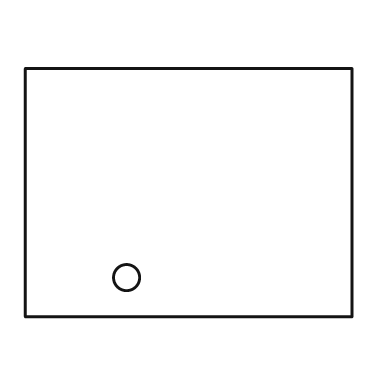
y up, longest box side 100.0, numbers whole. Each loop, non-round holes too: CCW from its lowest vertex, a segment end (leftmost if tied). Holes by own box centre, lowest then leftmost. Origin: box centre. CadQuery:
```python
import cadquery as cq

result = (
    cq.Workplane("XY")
    .moveTo(-50.0, -38.0)
    .lineTo(50.0, -38.0)
    .lineTo(50.0, 38.0)
    .lineTo(-50.0, 38.0)
    .close()
    .moveTo(-19.0, -26.0)
    .circle(4.0)
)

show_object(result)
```